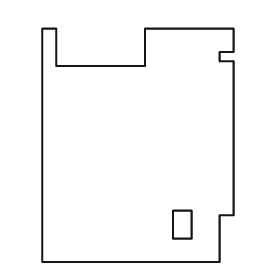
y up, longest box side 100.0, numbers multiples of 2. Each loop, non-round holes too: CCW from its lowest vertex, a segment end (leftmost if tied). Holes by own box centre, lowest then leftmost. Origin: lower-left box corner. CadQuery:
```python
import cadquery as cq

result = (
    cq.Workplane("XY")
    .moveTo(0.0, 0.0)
    .lineTo(76.0, 0.0)
    .lineTo(76.0, 20.0)
    .lineTo(82.0, 20.0)
    .lineTo(82.0, 86.0)
    .lineTo(76.0, 86.0)
    .lineTo(76.0, 90.0)
    .lineTo(82.0, 90.0)
    .lineTo(82.0, 100.0)
    .lineTo(44.0, 100.0)
    .lineTo(44.0, 84.0)
    .lineTo(6.0, 84.0)
    .lineTo(6.0, 100.0)
    .lineTo(0.0, 100.0)
    .close()
    .moveTo(56.0, 10.0)
    .lineTo(64.0, 10.0)
    .lineTo(64.0, 22.0)
    .lineTo(56.0, 22.0)
    .close()
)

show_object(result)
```